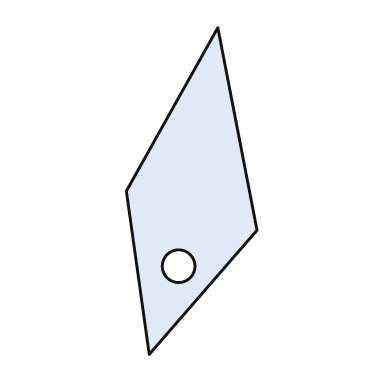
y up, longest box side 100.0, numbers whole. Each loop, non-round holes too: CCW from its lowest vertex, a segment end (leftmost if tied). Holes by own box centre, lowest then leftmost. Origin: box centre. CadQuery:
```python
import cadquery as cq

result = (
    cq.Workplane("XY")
    .moveTo(-13.0, -50.0)
    .lineTo(20.0, -12.0)
    .lineTo(8.0, 50.0)
    .lineTo(-20.0, 0.0)
    .close()
    .moveTo(-4.0, -23.0)
    .circle(5.0)
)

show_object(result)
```